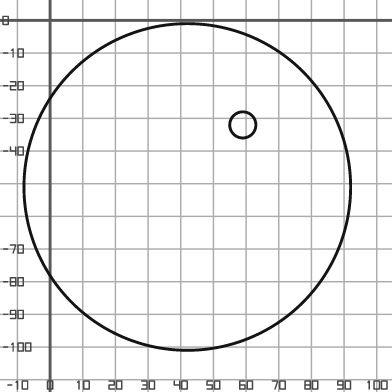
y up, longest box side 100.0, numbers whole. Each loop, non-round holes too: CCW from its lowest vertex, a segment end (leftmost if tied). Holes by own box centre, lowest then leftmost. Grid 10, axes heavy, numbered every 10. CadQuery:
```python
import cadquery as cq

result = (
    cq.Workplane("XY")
    .moveTo(42.0, -51.0)
    .circle(50.0)
    .moveTo(59.0, -32.0)
    .circle(4.0)
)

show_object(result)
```